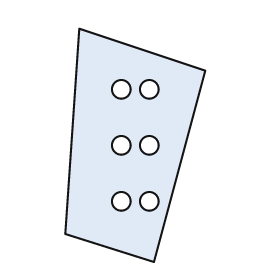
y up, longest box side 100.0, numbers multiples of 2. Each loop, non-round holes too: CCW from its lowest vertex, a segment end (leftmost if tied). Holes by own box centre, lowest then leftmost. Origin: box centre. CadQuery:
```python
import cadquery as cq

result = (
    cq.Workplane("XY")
    .moveTo(8.0, -50.0)
    .lineTo(30.0, 32.0)
    .lineTo(-24.0, 50.0)
    .lineTo(-30.0, -38.0)
    .close()
    .moveTo(-6.0, -24.0)
    .circle(4.0)
    .moveTo(6.0, -24.0)
    .circle(4.0)
    .moveTo(-6.0, 0.0)
    .circle(4.0)
    .moveTo(6.0, 0.0)
    .circle(4.0)
    .moveTo(-6.0, 24.0)
    .circle(4.0)
    .moveTo(6.0, 24.0)
    .circle(4.0)
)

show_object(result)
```